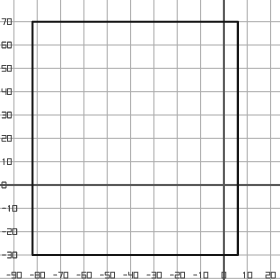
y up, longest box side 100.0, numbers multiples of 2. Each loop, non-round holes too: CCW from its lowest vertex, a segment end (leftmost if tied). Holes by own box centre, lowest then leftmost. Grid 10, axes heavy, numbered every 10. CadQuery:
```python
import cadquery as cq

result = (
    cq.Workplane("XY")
    .moveTo(-82.0, -30.0)
    .lineTo(6.0, -30.0)
    .lineTo(6.0, 70.0)
    .lineTo(-82.0, 70.0)
    .close()
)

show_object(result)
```